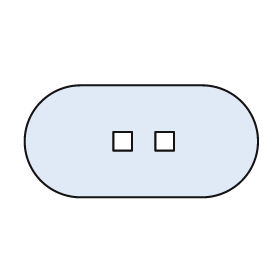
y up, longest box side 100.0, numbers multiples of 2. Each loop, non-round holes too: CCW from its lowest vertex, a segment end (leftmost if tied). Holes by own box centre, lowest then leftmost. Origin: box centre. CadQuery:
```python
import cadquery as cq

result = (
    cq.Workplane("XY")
    .moveTo(-26.0, -24.0)
    .lineTo(26.0, -24.0)
    .threePointArc((50.0, 0.0), (26.0, 24.0))
    .lineTo(-26.0, 24.0)
    .threePointArc((-50.0, 0.0), (-26.0, -24.0))
    .close()
    .moveTo(-12.0, -4.0)
    .lineTo(-4.0, -4.0)
    .lineTo(-4.0, 4.0)
    .lineTo(-12.0, 4.0)
    .close()
    .moveTo(6.0, -4.0)
    .lineTo(14.0, -4.0)
    .lineTo(14.0, 4.0)
    .lineTo(6.0, 4.0)
    .close()
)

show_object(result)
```